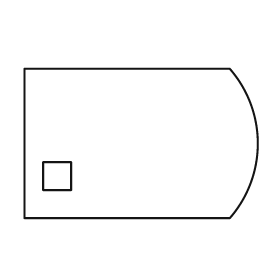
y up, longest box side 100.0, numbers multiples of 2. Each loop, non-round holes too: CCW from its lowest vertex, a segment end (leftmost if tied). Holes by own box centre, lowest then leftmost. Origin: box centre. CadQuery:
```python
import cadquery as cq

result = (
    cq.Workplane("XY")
    .moveTo(-50.0, -32.0)
    .lineTo(38.0, -32.0)
    .threePointArc((50.0, 0.0), (38.0, 32.0))
    .lineTo(-50.0, 32.0)
    .close()
    .moveTo(-42.0, -20.0)
    .lineTo(-30.0, -20.0)
    .lineTo(-30.0, -8.0)
    .lineTo(-42.0, -8.0)
    .close()
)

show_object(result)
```